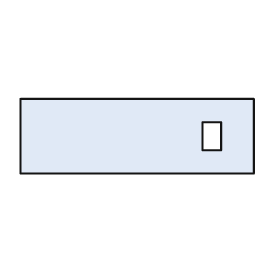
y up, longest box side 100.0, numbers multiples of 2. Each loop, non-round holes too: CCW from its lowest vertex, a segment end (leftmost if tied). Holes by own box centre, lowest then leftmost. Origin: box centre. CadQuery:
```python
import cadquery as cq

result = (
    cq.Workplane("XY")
    .moveTo(-50.0, -16.0)
    .lineTo(50.0, -16.0)
    .lineTo(50.0, 16.0)
    .lineTo(-50.0, 16.0)
    .close()
    .moveTo(28.0, -6.0)
    .lineTo(36.0, -6.0)
    .lineTo(36.0, 6.0)
    .lineTo(28.0, 6.0)
    .close()
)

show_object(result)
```